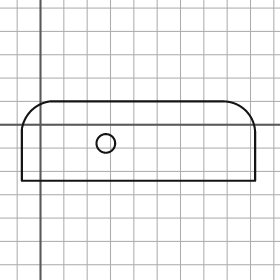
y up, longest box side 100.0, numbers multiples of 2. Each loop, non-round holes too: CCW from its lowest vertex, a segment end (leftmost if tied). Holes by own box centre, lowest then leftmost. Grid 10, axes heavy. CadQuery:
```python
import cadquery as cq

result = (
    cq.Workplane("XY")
    .moveTo(-8.0, -24.0)
    .lineTo(92.0, -24.0)
    .lineTo(92.0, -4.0)
    .threePointArc((88.0, 6.0), (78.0, 10.0))
    .lineTo(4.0, 10.0)
    .threePointArc((-4.0, 6.0), (-8.0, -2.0))
    .close()
    .moveTo(28.0, -8.0)
    .circle(4.0)
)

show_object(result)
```